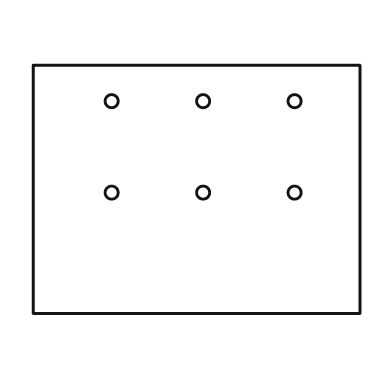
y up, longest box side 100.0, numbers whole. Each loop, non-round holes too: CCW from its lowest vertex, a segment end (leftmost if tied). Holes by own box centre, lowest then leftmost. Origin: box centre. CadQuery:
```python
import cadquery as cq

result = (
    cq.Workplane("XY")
    .moveTo(-50.0, -38.0)
    .lineTo(50.0, -38.0)
    .lineTo(50.0, 38.0)
    .lineTo(-50.0, 38.0)
    .close()
    .moveTo(-26.0, -1.0)
    .circle(2.0)
    .moveTo(2.0, -1.0)
    .circle(2.0)
    .moveTo(30.0, -1.0)
    .circle(2.0)
    .moveTo(-26.0, 27.0)
    .circle(2.0)
    .moveTo(2.0, 27.0)
    .circle(2.0)
    .moveTo(30.0, 27.0)
    .circle(2.0)
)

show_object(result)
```